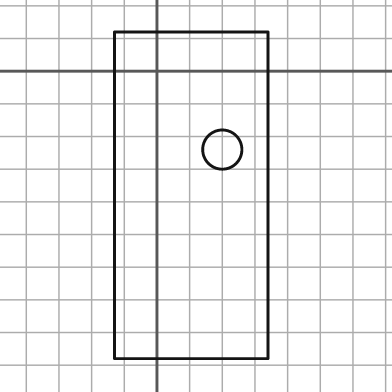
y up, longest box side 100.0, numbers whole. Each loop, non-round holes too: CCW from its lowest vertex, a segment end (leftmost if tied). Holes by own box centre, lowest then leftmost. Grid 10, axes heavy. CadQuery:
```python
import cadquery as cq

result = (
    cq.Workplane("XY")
    .moveTo(-13.0, -88.0)
    .lineTo(34.0, -88.0)
    .lineTo(34.0, 12.0)
    .lineTo(-13.0, 12.0)
    .close()
    .moveTo(20.0, -24.0)
    .circle(6.0)
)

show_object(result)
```